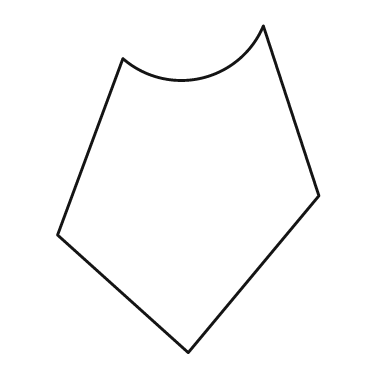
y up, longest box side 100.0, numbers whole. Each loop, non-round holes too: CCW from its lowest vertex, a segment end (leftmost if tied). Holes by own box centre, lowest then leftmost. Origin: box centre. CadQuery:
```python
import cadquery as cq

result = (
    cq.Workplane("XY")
    .moveTo(0.0, -50.0)
    .lineTo(40.0, -2.0)
    .lineTo(23.0, 50.0)
    .threePointArc((4.0, 34.0), (-20.0, 40.0))
    .lineTo(-40.0, -14.0)
    .close()
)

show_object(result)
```